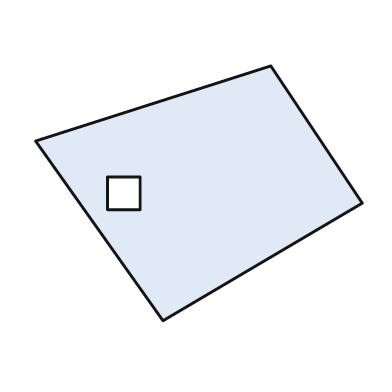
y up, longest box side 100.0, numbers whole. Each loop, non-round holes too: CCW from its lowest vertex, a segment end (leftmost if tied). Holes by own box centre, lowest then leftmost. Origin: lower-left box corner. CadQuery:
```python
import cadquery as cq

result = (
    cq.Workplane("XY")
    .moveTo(39.0, 0.0)
    .lineTo(100.0, 36.0)
    .lineTo(72.0, 78.0)
    .lineTo(0.0, 55.0)
    .close()
    .moveTo(22.0, 34.0)
    .lineTo(32.0, 34.0)
    .lineTo(32.0, 44.0)
    .lineTo(22.0, 44.0)
    .close()
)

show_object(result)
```